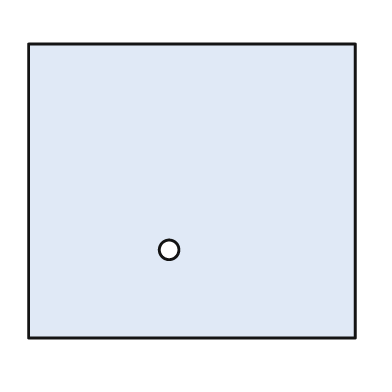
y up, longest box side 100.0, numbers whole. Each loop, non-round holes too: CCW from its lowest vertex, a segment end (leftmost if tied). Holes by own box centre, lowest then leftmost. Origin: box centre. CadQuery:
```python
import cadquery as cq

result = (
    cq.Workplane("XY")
    .moveTo(-50.0, -45.0)
    .lineTo(50.0, -45.0)
    .lineTo(50.0, 45.0)
    .lineTo(-50.0, 45.0)
    .close()
    .moveTo(-7.0, -18.0)
    .circle(3.0)
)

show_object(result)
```